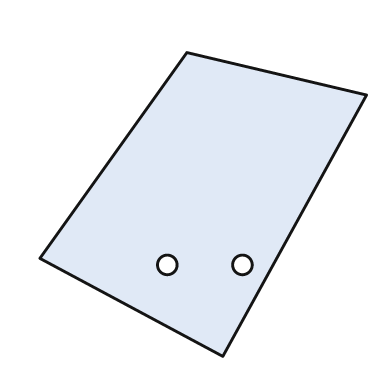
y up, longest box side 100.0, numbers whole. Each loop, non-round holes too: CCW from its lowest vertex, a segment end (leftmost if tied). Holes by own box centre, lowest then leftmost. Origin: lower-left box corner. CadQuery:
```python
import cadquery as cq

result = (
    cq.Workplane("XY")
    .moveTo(56.0, 0.0)
    .lineTo(100.0, 80.0)
    .lineTo(45.0, 93.0)
    .lineTo(0.0, 30.0)
    .close()
    .moveTo(39.0, 28.0)
    .circle(3.0)
    .moveTo(62.0, 28.0)
    .circle(3.0)
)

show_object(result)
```